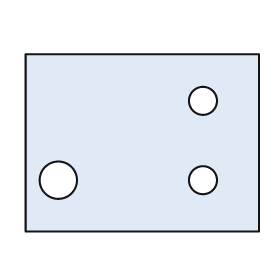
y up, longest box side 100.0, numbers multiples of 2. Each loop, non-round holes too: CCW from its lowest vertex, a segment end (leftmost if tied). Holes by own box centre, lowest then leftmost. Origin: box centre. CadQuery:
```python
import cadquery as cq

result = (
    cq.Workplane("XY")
    .moveTo(-50.0, -38.0)
    .lineTo(50.0, -38.0)
    .lineTo(50.0, 38.0)
    .lineTo(-50.0, 38.0)
    .close()
    .moveTo(-36.0, -16.0)
    .circle(8.0)
    .moveTo(26.0, -16.0)
    .circle(6.0)
    .moveTo(26.0, 18.0)
    .circle(6.0)
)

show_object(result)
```